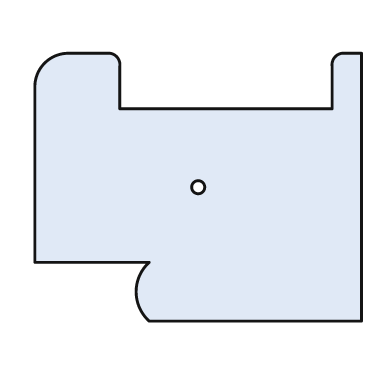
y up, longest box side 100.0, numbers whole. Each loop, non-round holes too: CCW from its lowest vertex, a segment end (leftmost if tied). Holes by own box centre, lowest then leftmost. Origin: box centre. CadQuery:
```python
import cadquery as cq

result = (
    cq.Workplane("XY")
    .moveTo(-15.0, -41.0)
    .lineTo(50.0, -41.0)
    .lineTo(50.0, 41.0)
    .lineTo(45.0, 41.0)
    .threePointArc((42.0, 40.0), (41.0, 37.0))
    .lineTo(41.0, 24.0)
    .lineTo(-24.0, 24.0)
    .lineTo(-24.0, 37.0)
    .threePointArc((-25.0, 40.0), (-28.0, 41.0))
    .lineTo(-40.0, 41.0)
    .threePointArc((-47.0, 38.0), (-50.0, 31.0))
    .lineTo(-50.0, -23.0)
    .lineTo(-15.0, -23.0)
    .threePointArc((-19.0, -32.0), (-15.0, -41.0))
    .close()
    .moveTo(0.0, 0.0)
    .circle(2.0)
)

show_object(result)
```